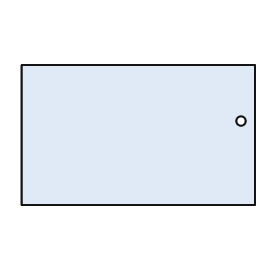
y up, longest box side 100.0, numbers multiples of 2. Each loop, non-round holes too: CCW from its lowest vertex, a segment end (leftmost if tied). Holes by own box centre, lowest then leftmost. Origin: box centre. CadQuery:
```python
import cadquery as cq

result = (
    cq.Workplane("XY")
    .moveTo(-50.0, -30.0)
    .lineTo(50.0, -30.0)
    .lineTo(50.0, 30.0)
    .lineTo(-50.0, 30.0)
    .close()
    .moveTo(44.0, 6.0)
    .circle(2.0)
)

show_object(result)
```